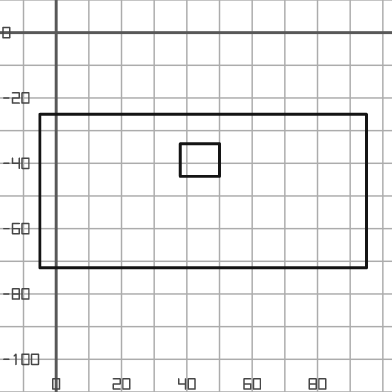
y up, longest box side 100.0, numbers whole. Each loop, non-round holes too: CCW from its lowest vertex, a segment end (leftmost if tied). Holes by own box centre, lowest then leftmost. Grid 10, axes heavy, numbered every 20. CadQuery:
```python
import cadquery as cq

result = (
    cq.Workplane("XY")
    .moveTo(-5.0, -72.0)
    .lineTo(95.0, -72.0)
    .lineTo(95.0, -25.0)
    .lineTo(-5.0, -25.0)
    .close()
    .moveTo(38.0, -44.0)
    .lineTo(50.0, -44.0)
    .lineTo(50.0, -34.0)
    .lineTo(38.0, -34.0)
    .close()
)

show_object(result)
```